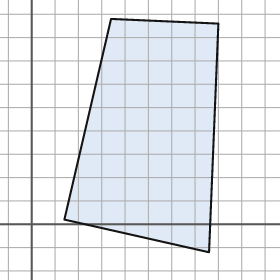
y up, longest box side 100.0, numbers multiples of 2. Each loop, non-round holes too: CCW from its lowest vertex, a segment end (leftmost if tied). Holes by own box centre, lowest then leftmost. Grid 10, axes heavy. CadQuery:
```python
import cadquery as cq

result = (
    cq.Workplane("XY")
    .moveTo(76.0, -12.0)
    .lineTo(80.0, 86.0)
    .lineTo(34.0, 88.0)
    .lineTo(14.0, 2.0)
    .close()
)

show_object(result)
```